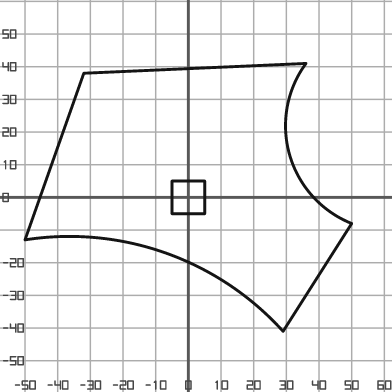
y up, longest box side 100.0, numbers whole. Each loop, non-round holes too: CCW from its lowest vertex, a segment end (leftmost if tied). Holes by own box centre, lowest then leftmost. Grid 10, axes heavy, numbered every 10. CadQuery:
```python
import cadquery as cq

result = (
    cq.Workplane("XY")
    .moveTo(29.0, -41.0)
    .lineTo(50.0, -8.0)
    .threePointArc((31.0, 13.0), (36.0, 41.0))
    .lineTo(-32.0, 38.0)
    .lineTo(-50.0, -13.0)
    .threePointArc((-7.0, -17.0), (29.0, -41.0))
    .close()
    .moveTo(-5.0, -5.0)
    .lineTo(5.0, -5.0)
    .lineTo(5.0, 5.0)
    .lineTo(-5.0, 5.0)
    .close()
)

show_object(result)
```